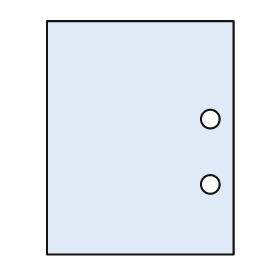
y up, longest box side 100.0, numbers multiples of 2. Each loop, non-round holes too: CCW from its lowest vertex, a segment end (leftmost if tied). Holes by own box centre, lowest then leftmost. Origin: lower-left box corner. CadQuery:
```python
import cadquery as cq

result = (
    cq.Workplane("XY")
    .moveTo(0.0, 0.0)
    .lineTo(80.0, 0.0)
    .lineTo(80.0, 100.0)
    .lineTo(0.0, 100.0)
    .close()
    .moveTo(70.0, 30.0)
    .circle(4.0)
    .moveTo(70.0, 58.0)
    .circle(4.0)
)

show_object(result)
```